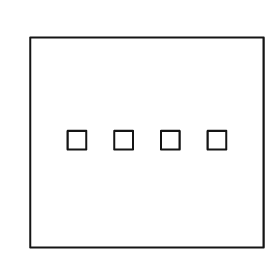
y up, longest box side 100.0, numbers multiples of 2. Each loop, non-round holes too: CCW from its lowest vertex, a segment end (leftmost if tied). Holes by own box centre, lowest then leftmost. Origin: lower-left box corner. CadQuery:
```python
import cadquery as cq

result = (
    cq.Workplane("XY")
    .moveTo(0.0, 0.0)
    .lineTo(100.0, 0.0)
    .lineTo(100.0, 90.0)
    .lineTo(0.0, 90.0)
    .close()
    .moveTo(16.0, 42.0)
    .lineTo(24.0, 42.0)
    .lineTo(24.0, 50.0)
    .lineTo(16.0, 50.0)
    .close()
    .moveTo(36.0, 42.0)
    .lineTo(44.0, 42.0)
    .lineTo(44.0, 50.0)
    .lineTo(36.0, 50.0)
    .close()
    .moveTo(56.0, 42.0)
    .lineTo(64.0, 42.0)
    .lineTo(64.0, 50.0)
    .lineTo(56.0, 50.0)
    .close()
    .moveTo(76.0, 42.0)
    .lineTo(84.0, 42.0)
    .lineTo(84.0, 50.0)
    .lineTo(76.0, 50.0)
    .close()
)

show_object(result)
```